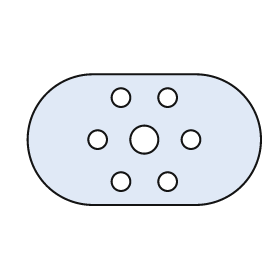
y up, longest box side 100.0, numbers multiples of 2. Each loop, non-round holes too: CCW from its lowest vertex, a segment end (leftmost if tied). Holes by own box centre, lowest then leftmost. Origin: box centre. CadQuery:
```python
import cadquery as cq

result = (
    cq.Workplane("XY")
    .moveTo(-22.0, -28.0)
    .lineTo(22.0, -28.0)
    .threePointArc((50.0, 0.0), (22.0, 28.0))
    .lineTo(-22.0, 28.0)
    .threePointArc((-50.0, 0.0), (-22.0, -28.0))
    .close()
    .moveTo(-10.0, -18.0)
    .circle(4.0)
    .moveTo(10.0, -18.0)
    .circle(4.0)
    .moveTo(-20.0, 0.0)
    .circle(4.0)
    .moveTo(0.0, 0.0)
    .circle(6.0)
    .moveTo(20.0, 0.0)
    .circle(4.0)
    .moveTo(-10.0, 18.0)
    .circle(4.0)
    .moveTo(10.0, 18.0)
    .circle(4.0)
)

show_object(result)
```